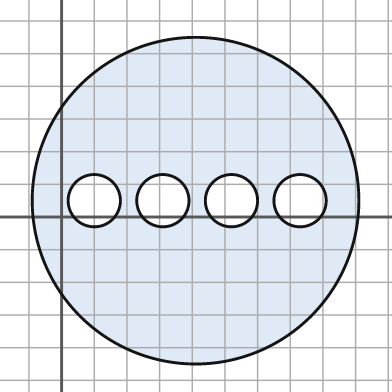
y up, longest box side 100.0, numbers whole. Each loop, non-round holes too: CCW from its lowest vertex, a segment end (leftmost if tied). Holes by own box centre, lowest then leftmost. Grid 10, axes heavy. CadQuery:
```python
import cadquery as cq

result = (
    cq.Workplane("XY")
    .moveTo(41.0, 5.0)
    .circle(50.0)
    .moveTo(10.0, 5.0)
    .circle(8.0)
    .moveTo(31.0, 5.0)
    .circle(8.0)
    .moveTo(52.0, 5.0)
    .circle(8.0)
    .moveTo(73.0, 5.0)
    .circle(8.0)
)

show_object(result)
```